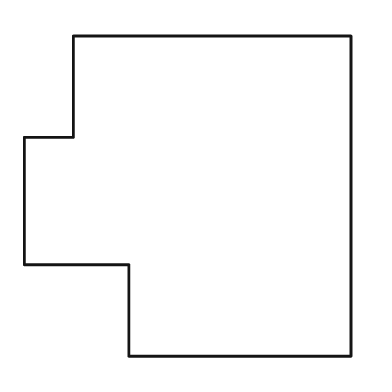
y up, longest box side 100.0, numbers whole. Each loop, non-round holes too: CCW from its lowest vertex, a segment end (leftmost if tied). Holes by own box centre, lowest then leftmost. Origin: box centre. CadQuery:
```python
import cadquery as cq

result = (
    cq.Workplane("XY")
    .moveTo(-18.0, -49.0)
    .lineTo(50.0, -49.0)
    .lineTo(50.0, 49.0)
    .lineTo(-35.0, 49.0)
    .lineTo(-35.0, 18.0)
    .lineTo(-50.0, 18.0)
    .lineTo(-50.0, -21.0)
    .lineTo(-18.0, -21.0)
    .close()
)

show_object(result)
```